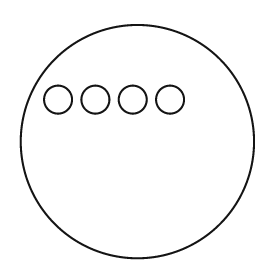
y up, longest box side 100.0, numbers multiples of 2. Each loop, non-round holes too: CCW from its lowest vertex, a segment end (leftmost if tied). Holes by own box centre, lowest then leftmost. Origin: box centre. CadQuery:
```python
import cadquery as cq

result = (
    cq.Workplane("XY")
    .moveTo(0.0, 0.0)
    .circle(50.0)
    .moveTo(-34.0, 18.0)
    .circle(6.0)
    .moveTo(-18.0, 18.0)
    .circle(6.0)
    .moveTo(-2.0, 18.0)
    .circle(6.0)
    .moveTo(14.0, 18.0)
    .circle(6.0)
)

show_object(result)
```